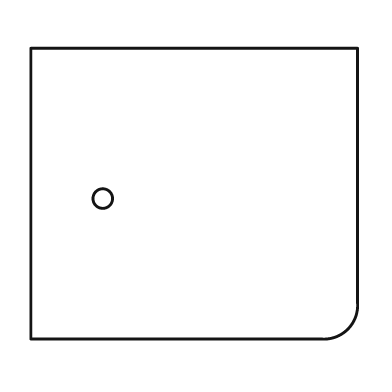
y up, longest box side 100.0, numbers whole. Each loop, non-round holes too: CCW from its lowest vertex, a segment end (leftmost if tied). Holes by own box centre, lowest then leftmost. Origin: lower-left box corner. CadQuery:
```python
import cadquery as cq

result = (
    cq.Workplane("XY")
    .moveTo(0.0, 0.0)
    .lineTo(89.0, 0.0)
    .threePointArc((97.0, 3.0), (100.0, 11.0))
    .lineTo(100.0, 89.0)
    .lineTo(0.0, 89.0)
    .close()
    .moveTo(22.0, 43.0)
    .circle(3.0)
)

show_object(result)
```